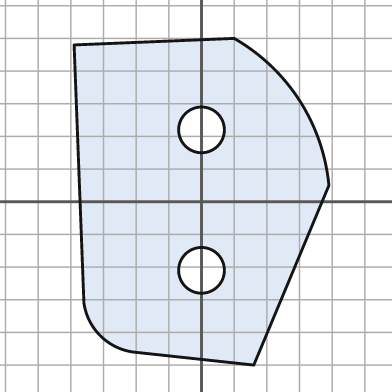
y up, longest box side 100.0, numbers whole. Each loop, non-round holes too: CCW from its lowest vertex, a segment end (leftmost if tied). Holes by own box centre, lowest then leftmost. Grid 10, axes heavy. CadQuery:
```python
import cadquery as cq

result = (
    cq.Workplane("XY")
    .moveTo(16.0, -50.0)
    .lineTo(39.0, 5.0)
    .threePointArc((30.0, 31.0), (10.0, 50.0))
    .lineTo(-39.0, 48.0)
    .lineTo(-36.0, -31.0)
    .threePointArc((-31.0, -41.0), (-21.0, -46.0))
    .close()
    .moveTo(0.0, -21.0)
    .circle(7.0)
    .moveTo(0.0, 22.0)
    .circle(7.0)
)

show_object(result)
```